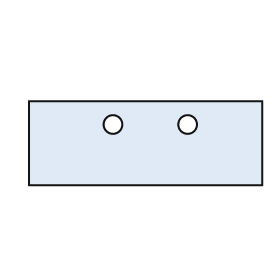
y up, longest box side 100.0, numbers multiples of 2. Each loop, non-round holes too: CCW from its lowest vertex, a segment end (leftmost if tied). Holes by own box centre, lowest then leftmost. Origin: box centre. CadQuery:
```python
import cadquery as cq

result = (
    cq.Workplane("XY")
    .moveTo(-50.0, -18.0)
    .lineTo(50.0, -18.0)
    .lineTo(50.0, 18.0)
    .lineTo(-50.0, 18.0)
    .close()
    .moveTo(-14.0, 8.0)
    .circle(4.0)
    .moveTo(18.0, 8.0)
    .circle(4.0)
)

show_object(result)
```